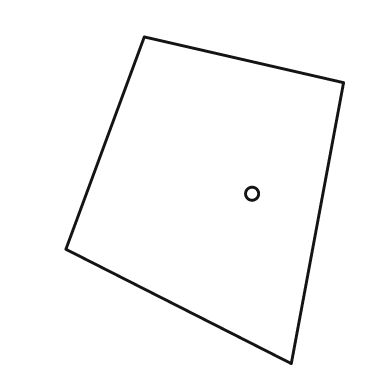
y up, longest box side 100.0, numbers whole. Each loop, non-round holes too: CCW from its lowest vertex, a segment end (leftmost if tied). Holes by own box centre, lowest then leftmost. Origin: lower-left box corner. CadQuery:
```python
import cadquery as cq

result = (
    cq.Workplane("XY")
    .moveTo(69.0, 0.0)
    .lineTo(85.0, 86.0)
    .lineTo(24.0, 100.0)
    .lineTo(0.0, 35.0)
    .close()
    .moveTo(57.0, 52.0)
    .circle(2.0)
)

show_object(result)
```